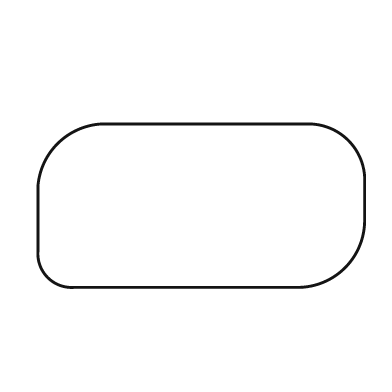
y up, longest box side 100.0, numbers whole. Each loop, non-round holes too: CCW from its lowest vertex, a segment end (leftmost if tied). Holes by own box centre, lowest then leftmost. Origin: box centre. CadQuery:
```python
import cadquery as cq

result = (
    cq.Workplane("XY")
    .moveTo(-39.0, -25.0)
    .lineTo(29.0, -25.0)
    .threePointArc((44.0, -19.0), (50.0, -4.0))
    .lineTo(50.0, 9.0)
    .threePointArc((45.0, 20.0), (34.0, 25.0))
    .lineTo(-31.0, 25.0)
    .threePointArc((-44.0, 19.0), (-50.0, 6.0))
    .lineTo(-50.0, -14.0)
    .threePointArc((-47.0, -22.0), (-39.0, -25.0))
    .close()
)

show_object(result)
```